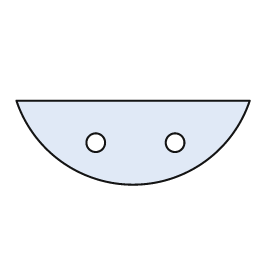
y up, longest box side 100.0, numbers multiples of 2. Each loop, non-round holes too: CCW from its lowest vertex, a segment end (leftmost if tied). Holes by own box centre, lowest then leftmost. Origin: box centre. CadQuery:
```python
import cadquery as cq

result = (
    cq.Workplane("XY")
    .moveTo(-50.0, 18.0)
    .threePointArc((0.0, -18.0), (50.0, 18.0))
    .close()
    .moveTo(-16.0, 0.0)
    .circle(4.0)
    .moveTo(18.0, 0.0)
    .circle(4.0)
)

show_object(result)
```